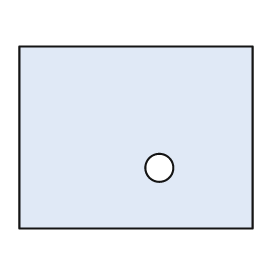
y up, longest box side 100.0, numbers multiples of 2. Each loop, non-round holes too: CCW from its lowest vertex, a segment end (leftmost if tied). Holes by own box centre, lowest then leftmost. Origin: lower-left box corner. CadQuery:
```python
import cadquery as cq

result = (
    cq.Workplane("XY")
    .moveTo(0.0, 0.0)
    .lineTo(100.0, 0.0)
    .lineTo(100.0, 78.0)
    .lineTo(0.0, 78.0)
    .close()
    .moveTo(60.0, 26.0)
    .circle(6.0)
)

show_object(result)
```